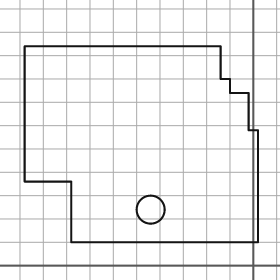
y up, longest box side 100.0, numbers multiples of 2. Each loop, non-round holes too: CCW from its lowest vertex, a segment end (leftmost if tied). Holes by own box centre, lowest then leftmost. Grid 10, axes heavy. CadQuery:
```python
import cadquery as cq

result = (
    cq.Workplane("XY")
    .moveTo(-78.0, 10.0)
    .lineTo(2.0, 10.0)
    .lineTo(2.0, 58.0)
    .lineTo(-2.0, 58.0)
    .lineTo(-2.0, 74.0)
    .lineTo(-10.0, 74.0)
    .lineTo(-10.0, 80.0)
    .lineTo(-14.0, 80.0)
    .lineTo(-14.0, 94.0)
    .lineTo(-98.0, 94.0)
    .lineTo(-98.0, 36.0)
    .lineTo(-78.0, 36.0)
    .close()
    .moveTo(-44.0, 24.0)
    .circle(6.0)
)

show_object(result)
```